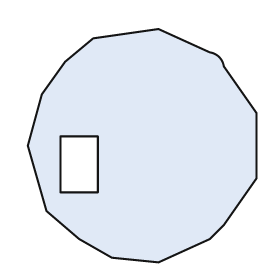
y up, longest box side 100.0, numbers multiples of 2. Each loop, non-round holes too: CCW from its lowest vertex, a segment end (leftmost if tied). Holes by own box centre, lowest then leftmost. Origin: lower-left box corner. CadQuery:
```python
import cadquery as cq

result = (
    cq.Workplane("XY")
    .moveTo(56.0, 0.0)
    .lineTo(78.0, 10.0)
    .lineTo(84.0, 16.0)
    .lineTo(98.0, 36.0)
    .lineTo(98.0, 64.0)
    .lineTo(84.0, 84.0)
    .threePointArc((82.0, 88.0), (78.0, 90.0))
    .lineTo(56.0, 100.0)
    .lineTo(28.0, 96.0)
    .lineTo(16.0, 86.0)
    .lineTo(6.0, 72.0)
    .lineTo(0.0, 50.0)
    .lineTo(8.0, 22.0)
    .lineTo(22.0, 10.0)
    .lineTo(36.0, 2.0)
    .close()
    .moveTo(14.0, 30.0)
    .lineTo(30.0, 30.0)
    .lineTo(30.0, 54.0)
    .lineTo(14.0, 54.0)
    .close()
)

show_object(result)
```